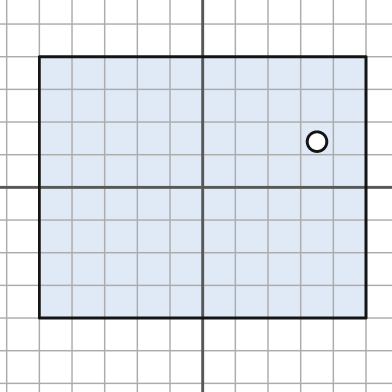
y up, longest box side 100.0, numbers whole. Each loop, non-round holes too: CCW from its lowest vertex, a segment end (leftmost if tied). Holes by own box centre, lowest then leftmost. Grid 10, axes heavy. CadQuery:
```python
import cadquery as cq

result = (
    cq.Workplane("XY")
    .moveTo(-50.0, -40.0)
    .lineTo(50.0, -40.0)
    .lineTo(50.0, 40.0)
    .lineTo(-50.0, 40.0)
    .close()
    .moveTo(35.0, 14.0)
    .circle(3.0)
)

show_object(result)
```